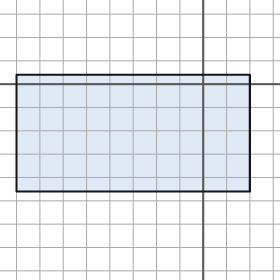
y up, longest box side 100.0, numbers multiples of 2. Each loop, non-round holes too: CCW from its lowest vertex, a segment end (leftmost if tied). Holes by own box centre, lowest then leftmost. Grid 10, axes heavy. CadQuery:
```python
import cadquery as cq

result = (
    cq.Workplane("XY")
    .moveTo(-80.0, -46.0)
    .lineTo(20.0, -46.0)
    .lineTo(20.0, 4.0)
    .lineTo(-80.0, 4.0)
    .close()
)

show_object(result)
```